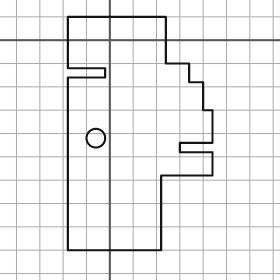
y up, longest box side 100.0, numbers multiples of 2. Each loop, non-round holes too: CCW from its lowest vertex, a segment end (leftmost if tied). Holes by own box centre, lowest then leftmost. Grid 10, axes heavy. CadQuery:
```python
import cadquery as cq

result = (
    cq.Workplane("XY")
    .moveTo(-18.0, -90.0)
    .lineTo(22.0, -90.0)
    .lineTo(22.0, -58.0)
    .lineTo(44.0, -58.0)
    .lineTo(44.0, -48.0)
    .lineTo(30.0, -48.0)
    .lineTo(30.0, -44.0)
    .lineTo(44.0, -44.0)
    .lineTo(44.0, -30.0)
    .lineTo(40.0, -30.0)
    .lineTo(40.0, -18.0)
    .lineTo(34.0, -18.0)
    .lineTo(34.0, -10.0)
    .lineTo(24.0, -10.0)
    .lineTo(24.0, 10.0)
    .lineTo(-18.0, 10.0)
    .lineTo(-18.0, -12.0)
    .lineTo(-2.0, -12.0)
    .lineTo(-2.0, -16.0)
    .lineTo(-18.0, -16.0)
    .close()
    .moveTo(-6.0, -42.0)
    .circle(4.0)
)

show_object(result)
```